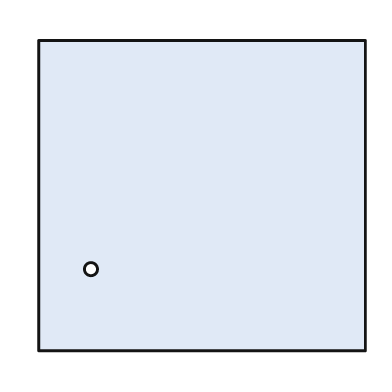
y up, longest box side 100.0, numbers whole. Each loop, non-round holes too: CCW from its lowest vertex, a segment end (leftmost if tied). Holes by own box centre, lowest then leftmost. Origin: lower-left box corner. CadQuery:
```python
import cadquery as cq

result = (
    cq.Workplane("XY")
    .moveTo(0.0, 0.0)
    .lineTo(100.0, 0.0)
    .lineTo(100.0, 95.0)
    .lineTo(0.0, 95.0)
    .close()
    .moveTo(16.0, 25.0)
    .circle(2.0)
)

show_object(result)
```